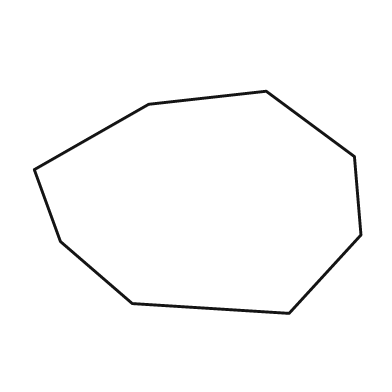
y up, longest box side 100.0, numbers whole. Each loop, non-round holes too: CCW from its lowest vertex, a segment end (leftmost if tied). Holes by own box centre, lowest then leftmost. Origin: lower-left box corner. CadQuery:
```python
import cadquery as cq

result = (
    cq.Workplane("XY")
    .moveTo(78.0, 0.0)
    .lineTo(100.0, 24.0)
    .lineTo(98.0, 48.0)
    .lineTo(71.0, 68.0)
    .lineTo(35.0, 64.0)
    .lineTo(0.0, 44.0)
    .lineTo(8.0, 22.0)
    .lineTo(30.0, 3.0)
    .close()
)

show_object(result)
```